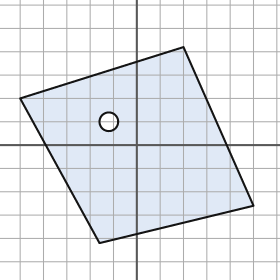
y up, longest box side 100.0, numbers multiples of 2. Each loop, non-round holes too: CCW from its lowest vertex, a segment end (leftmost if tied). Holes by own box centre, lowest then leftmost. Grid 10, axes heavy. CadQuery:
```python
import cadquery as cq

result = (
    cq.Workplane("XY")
    .moveTo(-16.0, -42.0)
    .lineTo(50.0, -26.0)
    .lineTo(20.0, 42.0)
    .lineTo(-50.0, 20.0)
    .close()
    .moveTo(-12.0, 10.0)
    .circle(4.0)
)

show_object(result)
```